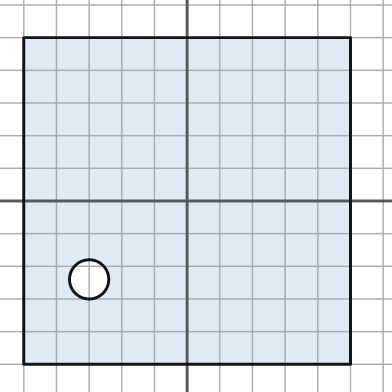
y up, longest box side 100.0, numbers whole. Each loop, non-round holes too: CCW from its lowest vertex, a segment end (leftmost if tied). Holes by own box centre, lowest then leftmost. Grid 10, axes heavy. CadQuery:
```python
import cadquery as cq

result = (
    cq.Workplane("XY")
    .moveTo(-50.0, -50.0)
    .lineTo(50.0, -50.0)
    .lineTo(50.0, 50.0)
    .lineTo(-50.0, 50.0)
    .close()
    .moveTo(-30.0, -24.0)
    .circle(6.0)
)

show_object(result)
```